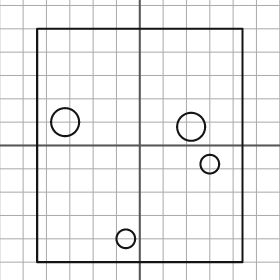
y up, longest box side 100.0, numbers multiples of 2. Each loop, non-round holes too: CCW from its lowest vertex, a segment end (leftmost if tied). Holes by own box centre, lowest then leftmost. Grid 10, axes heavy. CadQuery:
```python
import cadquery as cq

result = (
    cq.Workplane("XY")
    .moveTo(-44.0, -50.0)
    .lineTo(44.0, -50.0)
    .lineTo(44.0, 50.0)
    .lineTo(-44.0, 50.0)
    .close()
    .moveTo(-6.0, -40.0)
    .circle(4.0)
    .moveTo(30.0, -8.0)
    .circle(4.0)
    .moveTo(22.0, 8.0)
    .circle(6.0)
    .moveTo(-32.0, 10.0)
    .circle(6.0)
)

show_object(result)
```